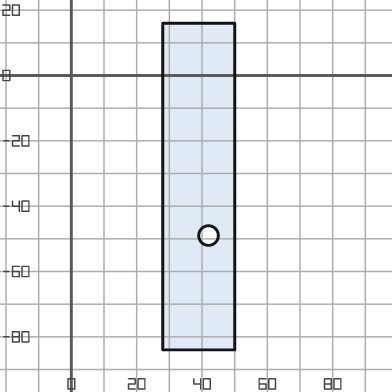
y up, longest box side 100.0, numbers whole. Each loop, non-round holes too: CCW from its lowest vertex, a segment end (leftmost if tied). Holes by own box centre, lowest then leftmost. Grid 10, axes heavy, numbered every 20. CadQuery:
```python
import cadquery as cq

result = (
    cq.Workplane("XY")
    .moveTo(28.0, -84.0)
    .lineTo(50.0, -84.0)
    .lineTo(50.0, 16.0)
    .lineTo(28.0, 16.0)
    .close()
    .moveTo(42.0, -49.0)
    .circle(3.0)
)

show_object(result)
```